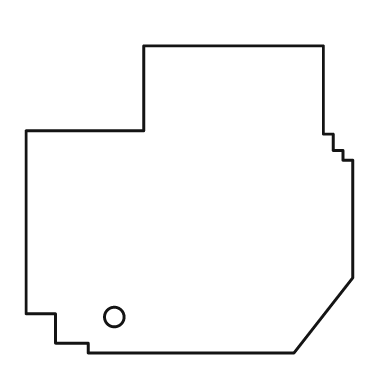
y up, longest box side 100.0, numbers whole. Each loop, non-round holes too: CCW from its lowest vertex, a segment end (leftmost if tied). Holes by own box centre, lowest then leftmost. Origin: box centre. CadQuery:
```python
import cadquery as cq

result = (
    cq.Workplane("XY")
    .moveTo(-31.0, -47.0)
    .lineTo(32.0, -47.0)
    .lineTo(50.0, -24.0)
    .lineTo(50.0, 12.0)
    .lineTo(47.0, 12.0)
    .lineTo(47.0, 15.0)
    .lineTo(44.0, 15.0)
    .lineTo(44.0, 20.0)
    .lineTo(41.0, 20.0)
    .lineTo(41.0, 47.0)
    .lineTo(-14.0, 47.0)
    .lineTo(-14.0, 21.0)
    .lineTo(-50.0, 21.0)
    .lineTo(-50.0, -35.0)
    .lineTo(-41.0, -35.0)
    .lineTo(-41.0, -44.0)
    .lineTo(-31.0, -44.0)
    .close()
    .moveTo(-23.0, -36.0)
    .circle(3.0)
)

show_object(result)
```